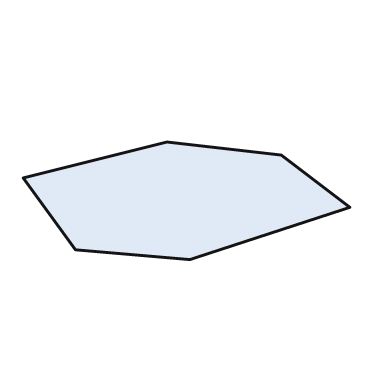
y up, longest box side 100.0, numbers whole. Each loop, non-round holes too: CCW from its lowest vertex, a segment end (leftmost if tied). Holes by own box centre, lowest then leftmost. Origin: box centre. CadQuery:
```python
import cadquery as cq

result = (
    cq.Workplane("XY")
    .moveTo(1.0, -18.0)
    .lineTo(50.0, -2.0)
    .lineTo(29.0, 14.0)
    .lineTo(-6.0, 18.0)
    .lineTo(-50.0, 7.0)
    .lineTo(-34.0, -15.0)
    .close()
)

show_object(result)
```